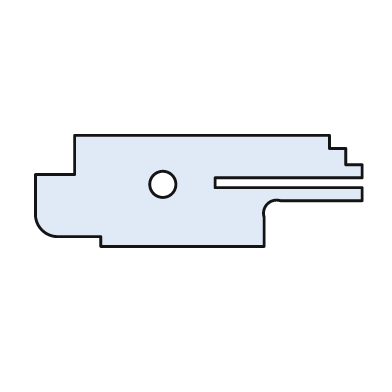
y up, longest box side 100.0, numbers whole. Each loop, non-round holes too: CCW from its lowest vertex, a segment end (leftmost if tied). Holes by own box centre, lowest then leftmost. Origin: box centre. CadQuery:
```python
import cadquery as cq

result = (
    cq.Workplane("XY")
    .moveTo(-30.0, -17.0)
    .lineTo(20.0, -17.0)
    .lineTo(20.0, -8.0)
    .threePointArc((21.0, -4.0), (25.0, -3.0))
    .lineTo(50.0, -3.0)
    .lineTo(50.0, 1.0)
    .lineTo(5.0, 1.0)
    .lineTo(5.0, 4.0)
    .lineTo(50.0, 4.0)
    .lineTo(50.0, 8.0)
    .lineTo(45.0, 8.0)
    .lineTo(45.0, 13.0)
    .lineTo(40.0, 13.0)
    .lineTo(40.0, 17.0)
    .lineTo(-38.0, 17.0)
    .lineTo(-38.0, 5.0)
    .lineTo(-50.0, 5.0)
    .lineTo(-50.0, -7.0)
    .threePointArc((-48.0, -12.0), (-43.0, -14.0))
    .lineTo(-30.0, -14.0)
    .close()
    .moveTo(-11.0, 2.0)
    .circle(4.0)
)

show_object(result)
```